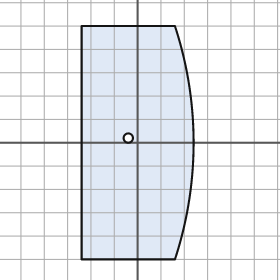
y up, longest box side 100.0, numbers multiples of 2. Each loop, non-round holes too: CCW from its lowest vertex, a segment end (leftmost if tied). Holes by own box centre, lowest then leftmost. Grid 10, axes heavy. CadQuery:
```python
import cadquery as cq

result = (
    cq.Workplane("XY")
    .moveTo(-24.0, -50.0)
    .lineTo(16.0, -50.0)
    .threePointArc((24.0, 0.0), (16.0, 50.0))
    .lineTo(-24.0, 50.0)
    .close()
    .moveTo(-4.0, 2.0)
    .circle(2.0)
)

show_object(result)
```